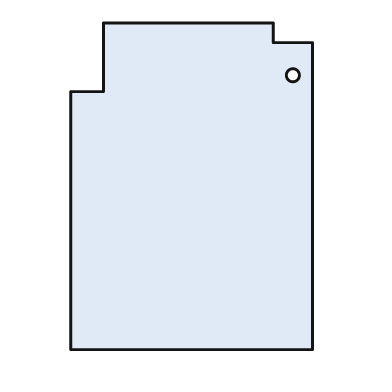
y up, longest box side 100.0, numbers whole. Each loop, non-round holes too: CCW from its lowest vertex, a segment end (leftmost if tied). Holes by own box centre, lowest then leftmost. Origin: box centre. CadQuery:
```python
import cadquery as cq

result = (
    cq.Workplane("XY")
    .moveTo(-37.0, -50.0)
    .lineTo(37.0, -50.0)
    .lineTo(37.0, 44.0)
    .lineTo(25.0, 44.0)
    .lineTo(25.0, 50.0)
    .lineTo(-27.0, 50.0)
    .lineTo(-27.0, 29.0)
    .lineTo(-37.0, 29.0)
    .close()
    .moveTo(31.0, 34.0)
    .circle(2.0)
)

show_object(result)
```